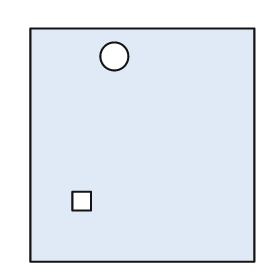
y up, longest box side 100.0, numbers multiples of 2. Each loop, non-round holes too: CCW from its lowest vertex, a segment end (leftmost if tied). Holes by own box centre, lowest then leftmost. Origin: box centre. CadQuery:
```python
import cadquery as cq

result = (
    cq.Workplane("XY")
    .moveTo(-48.0, -50.0)
    .lineTo(48.0, -50.0)
    .lineTo(48.0, 50.0)
    .lineTo(-48.0, 50.0)
    .close()
    .moveTo(-30.0, -28.0)
    .lineTo(-22.0, -28.0)
    .lineTo(-22.0, -20.0)
    .lineTo(-30.0, -20.0)
    .close()
    .moveTo(-12.0, 38.0)
    .circle(6.0)
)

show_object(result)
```